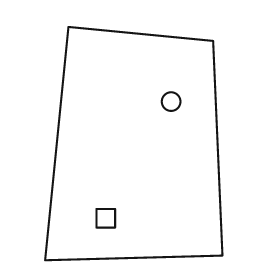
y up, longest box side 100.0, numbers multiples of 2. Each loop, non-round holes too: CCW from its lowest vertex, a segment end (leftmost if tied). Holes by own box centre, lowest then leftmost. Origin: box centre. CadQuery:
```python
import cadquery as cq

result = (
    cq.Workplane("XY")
    .moveTo(-38.0, -50.0)
    .lineTo(38.0, -48.0)
    .lineTo(34.0, 44.0)
    .lineTo(-28.0, 50.0)
    .close()
    .moveTo(-16.0, -36.0)
    .lineTo(-8.0, -36.0)
    .lineTo(-8.0, -28.0)
    .lineTo(-16.0, -28.0)
    .close()
    .moveTo(16.0, 18.0)
    .circle(4.0)
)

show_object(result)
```